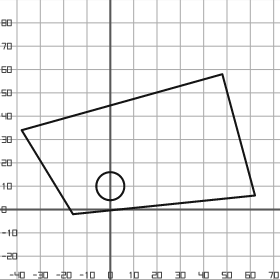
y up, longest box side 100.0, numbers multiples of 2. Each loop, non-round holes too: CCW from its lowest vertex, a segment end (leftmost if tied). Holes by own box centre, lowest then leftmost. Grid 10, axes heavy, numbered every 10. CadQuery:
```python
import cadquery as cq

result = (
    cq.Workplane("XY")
    .moveTo(-16.0, -2.0)
    .lineTo(62.0, 6.0)
    .lineTo(48.0, 58.0)
    .lineTo(-38.0, 34.0)
    .close()
    .moveTo(0.0, 10.0)
    .circle(6.0)
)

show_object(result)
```